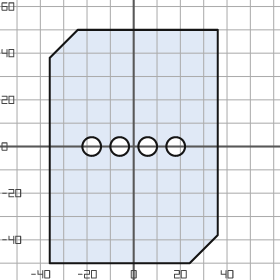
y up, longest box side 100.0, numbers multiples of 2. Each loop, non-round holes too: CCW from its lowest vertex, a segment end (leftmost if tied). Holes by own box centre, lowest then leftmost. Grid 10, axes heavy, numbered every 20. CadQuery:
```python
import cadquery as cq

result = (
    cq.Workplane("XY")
    .moveTo(-36.0, -50.0)
    .lineTo(24.0, -50.0)
    .lineTo(36.0, -38.0)
    .lineTo(36.0, 50.0)
    .lineTo(-24.0, 50.0)
    .lineTo(-36.0, 38.0)
    .close()
    .moveTo(-18.0, 0.0)
    .circle(4.0)
    .moveTo(-6.0, 0.0)
    .circle(4.0)
    .moveTo(6.0, 0.0)
    .circle(4.0)
    .moveTo(18.0, 0.0)
    .circle(4.0)
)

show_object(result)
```